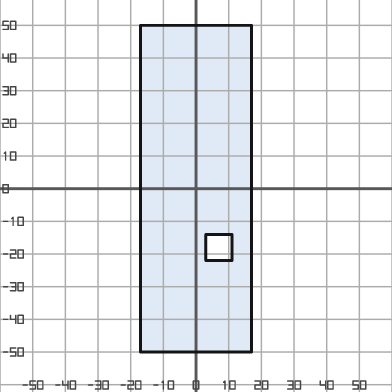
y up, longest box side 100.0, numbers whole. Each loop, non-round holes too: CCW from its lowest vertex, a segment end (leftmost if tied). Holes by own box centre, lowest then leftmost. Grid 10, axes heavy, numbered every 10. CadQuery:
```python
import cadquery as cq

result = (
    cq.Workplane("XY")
    .moveTo(-17.0, -50.0)
    .lineTo(17.0, -50.0)
    .lineTo(17.0, 50.0)
    .lineTo(-17.0, 50.0)
    .close()
    .moveTo(3.0, -22.0)
    .lineTo(11.0, -22.0)
    .lineTo(11.0, -14.0)
    .lineTo(3.0, -14.0)
    .close()
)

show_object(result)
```